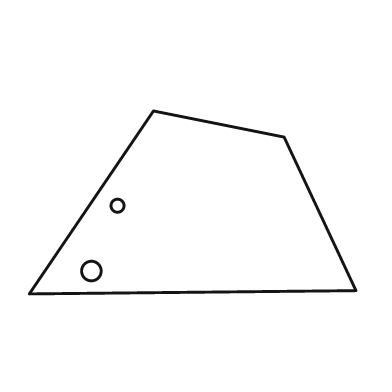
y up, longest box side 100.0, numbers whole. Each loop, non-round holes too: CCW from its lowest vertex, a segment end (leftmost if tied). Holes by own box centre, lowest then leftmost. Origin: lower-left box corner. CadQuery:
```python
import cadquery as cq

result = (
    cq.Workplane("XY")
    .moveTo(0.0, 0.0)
    .lineTo(100.0, 1.0)
    .lineTo(78.0, 48.0)
    .lineTo(38.0, 56.0)
    .close()
    .moveTo(19.0, 7.0)
    .circle(3.0)
    .moveTo(27.0, 27.0)
    .circle(2.0)
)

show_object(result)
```